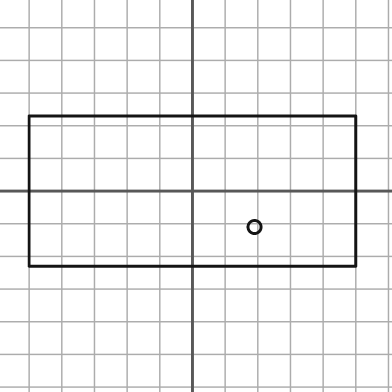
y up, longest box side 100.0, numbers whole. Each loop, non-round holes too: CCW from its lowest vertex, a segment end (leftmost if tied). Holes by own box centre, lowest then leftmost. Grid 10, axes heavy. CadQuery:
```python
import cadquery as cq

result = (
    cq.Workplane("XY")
    .moveTo(-50.0, -23.0)
    .lineTo(50.0, -23.0)
    .lineTo(50.0, 23.0)
    .lineTo(-50.0, 23.0)
    .close()
    .moveTo(19.0, -11.0)
    .circle(2.0)
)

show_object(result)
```